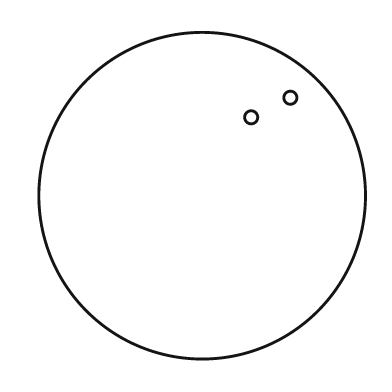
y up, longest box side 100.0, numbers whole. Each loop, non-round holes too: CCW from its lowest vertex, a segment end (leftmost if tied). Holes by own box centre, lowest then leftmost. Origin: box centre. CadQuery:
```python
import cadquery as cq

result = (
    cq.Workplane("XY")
    .moveTo(0.0, 0.0)
    .circle(50.0)
    .moveTo(15.0, 24.0)
    .circle(2.0)
    .moveTo(27.0, 30.0)
    .circle(2.0)
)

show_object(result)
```